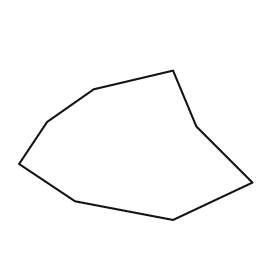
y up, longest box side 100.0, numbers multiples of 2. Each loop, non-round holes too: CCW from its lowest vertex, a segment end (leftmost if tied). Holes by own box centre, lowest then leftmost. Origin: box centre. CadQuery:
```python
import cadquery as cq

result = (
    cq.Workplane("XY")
    .moveTo(16.0, -32.0)
    .lineTo(50.0, -16.0)
    .lineTo(26.0, 8.0)
    .lineTo(16.0, 32.0)
    .lineTo(-18.0, 24.0)
    .lineTo(-38.0, 10.0)
    .lineTo(-50.0, -8.0)
    .lineTo(-26.0, -24.0)
    .close()
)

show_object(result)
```